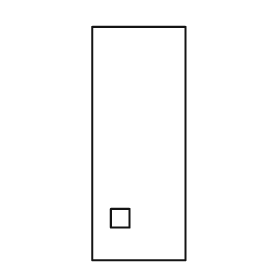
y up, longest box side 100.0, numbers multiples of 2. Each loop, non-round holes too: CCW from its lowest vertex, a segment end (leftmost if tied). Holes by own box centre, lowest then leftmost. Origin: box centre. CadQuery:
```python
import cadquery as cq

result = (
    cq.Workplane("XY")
    .moveTo(-20.0, -50.0)
    .lineTo(20.0, -50.0)
    .lineTo(20.0, 50.0)
    .lineTo(-20.0, 50.0)
    .close()
    .moveTo(-12.0, -36.0)
    .lineTo(-4.0, -36.0)
    .lineTo(-4.0, -28.0)
    .lineTo(-12.0, -28.0)
    .close()
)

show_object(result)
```